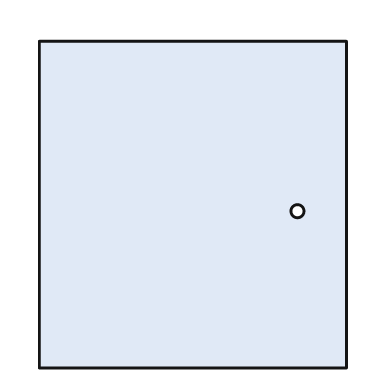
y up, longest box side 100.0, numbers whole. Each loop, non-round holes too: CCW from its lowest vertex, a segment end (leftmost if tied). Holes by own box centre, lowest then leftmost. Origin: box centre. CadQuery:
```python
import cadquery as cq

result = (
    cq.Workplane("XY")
    .moveTo(-47.0, -50.0)
    .lineTo(47.0, -50.0)
    .lineTo(47.0, 50.0)
    .lineTo(-47.0, 50.0)
    .close()
    .moveTo(32.0, -2.0)
    .circle(2.0)
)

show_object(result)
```